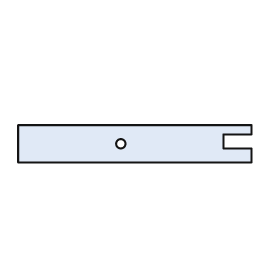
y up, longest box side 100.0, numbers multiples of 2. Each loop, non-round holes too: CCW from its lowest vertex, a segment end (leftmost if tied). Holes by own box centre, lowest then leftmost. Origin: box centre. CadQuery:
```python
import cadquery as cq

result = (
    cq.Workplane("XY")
    .moveTo(-50.0, -8.0)
    .lineTo(50.0, -8.0)
    .lineTo(50.0, -2.0)
    .lineTo(38.0, -2.0)
    .lineTo(38.0, 4.0)
    .lineTo(50.0, 4.0)
    .lineTo(50.0, 8.0)
    .lineTo(-50.0, 8.0)
    .close()
    .moveTo(-6.0, 0.0)
    .circle(2.0)
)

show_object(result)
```